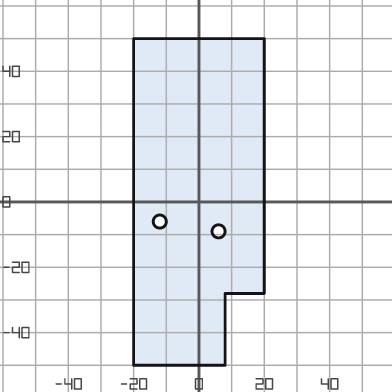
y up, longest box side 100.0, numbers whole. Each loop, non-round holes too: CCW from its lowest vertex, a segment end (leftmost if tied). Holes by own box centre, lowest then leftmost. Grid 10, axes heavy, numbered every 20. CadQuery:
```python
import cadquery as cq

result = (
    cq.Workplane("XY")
    .moveTo(-20.0, -50.0)
    .lineTo(8.0, -50.0)
    .lineTo(8.0, -28.0)
    .lineTo(20.0, -28.0)
    .lineTo(20.0, 50.0)
    .lineTo(-20.0, 50.0)
    .close()
    .moveTo(6.0, -9.0)
    .circle(2.0)
    .moveTo(-12.0, -6.0)
    .circle(2.0)
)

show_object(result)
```